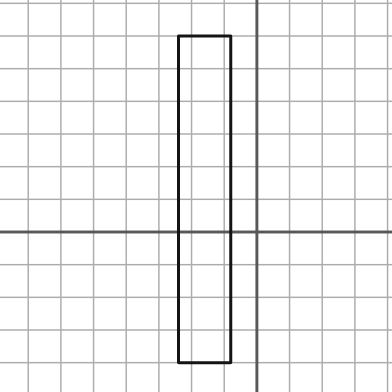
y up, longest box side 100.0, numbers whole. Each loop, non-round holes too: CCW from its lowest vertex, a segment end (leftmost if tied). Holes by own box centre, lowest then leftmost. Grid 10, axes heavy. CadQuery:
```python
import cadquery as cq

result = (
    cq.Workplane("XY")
    .moveTo(-24.0, -40.0)
    .lineTo(-8.0, -40.0)
    .lineTo(-8.0, 60.0)
    .lineTo(-24.0, 60.0)
    .close()
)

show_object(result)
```